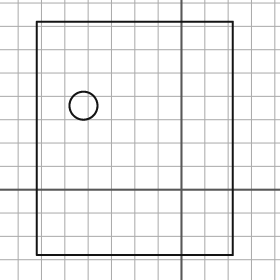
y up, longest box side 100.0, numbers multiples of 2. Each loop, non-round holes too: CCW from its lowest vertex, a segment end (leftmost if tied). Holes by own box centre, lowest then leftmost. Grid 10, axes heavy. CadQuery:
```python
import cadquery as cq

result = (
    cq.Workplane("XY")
    .moveTo(-62.0, -28.0)
    .lineTo(22.0, -28.0)
    .lineTo(22.0, 72.0)
    .lineTo(-62.0, 72.0)
    .close()
    .moveTo(-42.0, 36.0)
    .circle(6.0)
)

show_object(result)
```